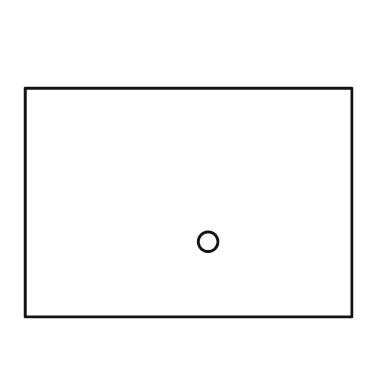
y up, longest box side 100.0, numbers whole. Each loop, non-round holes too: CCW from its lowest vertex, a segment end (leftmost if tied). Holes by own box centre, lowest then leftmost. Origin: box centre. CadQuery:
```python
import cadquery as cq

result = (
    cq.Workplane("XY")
    .moveTo(-50.0, -35.0)
    .lineTo(50.0, -35.0)
    .lineTo(50.0, 35.0)
    .lineTo(-50.0, 35.0)
    .close()
    .moveTo(6.0, -12.0)
    .circle(3.0)
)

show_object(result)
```